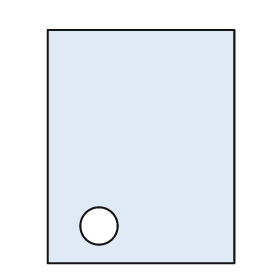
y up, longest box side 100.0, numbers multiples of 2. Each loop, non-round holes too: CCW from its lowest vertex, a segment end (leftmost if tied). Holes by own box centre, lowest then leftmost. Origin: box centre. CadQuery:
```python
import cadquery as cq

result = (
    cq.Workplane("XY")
    .moveTo(-40.0, -50.0)
    .lineTo(40.0, -50.0)
    .lineTo(40.0, 50.0)
    .lineTo(-40.0, 50.0)
    .close()
    .moveTo(-18.0, -34.0)
    .circle(8.0)
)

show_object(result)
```